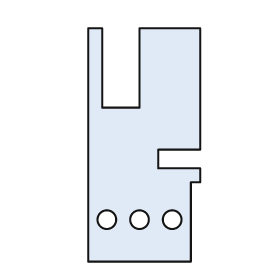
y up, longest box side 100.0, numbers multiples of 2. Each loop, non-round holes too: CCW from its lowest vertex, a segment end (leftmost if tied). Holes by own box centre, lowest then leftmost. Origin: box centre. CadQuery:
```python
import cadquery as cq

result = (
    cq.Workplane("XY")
    .moveTo(-24.0, -50.0)
    .lineTo(20.0, -50.0)
    .lineTo(20.0, -16.0)
    .lineTo(24.0, -16.0)
    .lineTo(24.0, -10.0)
    .lineTo(6.0, -10.0)
    .lineTo(6.0, -2.0)
    .lineTo(24.0, -2.0)
    .lineTo(24.0, 50.0)
    .lineTo(-2.0, 50.0)
    .lineTo(-2.0, 16.0)
    .lineTo(-18.0, 16.0)
    .lineTo(-18.0, 50.0)
    .lineTo(-24.0, 50.0)
    .close()
    .moveTo(-16.0, -32.0)
    .circle(4.0)
    .moveTo(-2.0, -32.0)
    .circle(4.0)
    .moveTo(12.0, -32.0)
    .circle(4.0)
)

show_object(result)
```